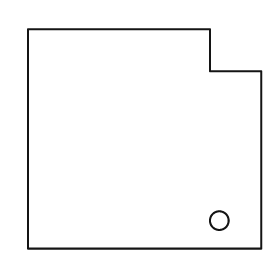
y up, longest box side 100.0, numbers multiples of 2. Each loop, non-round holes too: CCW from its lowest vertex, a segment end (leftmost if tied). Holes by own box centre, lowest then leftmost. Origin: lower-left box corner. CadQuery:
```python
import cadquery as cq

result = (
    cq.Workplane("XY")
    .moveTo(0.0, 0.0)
    .lineTo(100.0, 0.0)
    .lineTo(100.0, 76.0)
    .lineTo(78.0, 76.0)
    .lineTo(78.0, 94.0)
    .lineTo(0.0, 94.0)
    .close()
    .moveTo(82.0, 12.0)
    .circle(4.0)
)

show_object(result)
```